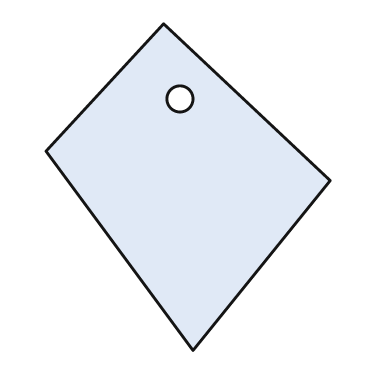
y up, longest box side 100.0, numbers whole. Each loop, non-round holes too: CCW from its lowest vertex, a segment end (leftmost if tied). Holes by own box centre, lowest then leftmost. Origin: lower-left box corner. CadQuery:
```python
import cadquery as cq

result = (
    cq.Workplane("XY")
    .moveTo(45.0, 0.0)
    .lineTo(87.0, 52.0)
    .lineTo(36.0, 100.0)
    .lineTo(0.0, 61.0)
    .close()
    .moveTo(41.0, 77.0)
    .circle(4.0)
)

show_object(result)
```